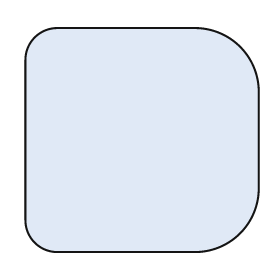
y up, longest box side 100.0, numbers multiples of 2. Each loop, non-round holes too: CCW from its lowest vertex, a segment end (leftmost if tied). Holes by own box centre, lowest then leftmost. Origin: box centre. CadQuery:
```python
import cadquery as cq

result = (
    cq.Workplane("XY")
    .moveTo(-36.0, -48.0)
    .lineTo(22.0, -48.0)
    .threePointArc((42.0, -40.0), (50.0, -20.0))
    .lineTo(50.0, 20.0)
    .threePointArc((42.0, 40.0), (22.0, 48.0))
    .lineTo(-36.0, 48.0)
    .threePointArc((-46.0, 44.0), (-50.0, 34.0))
    .lineTo(-50.0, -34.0)
    .threePointArc((-46.0, -44.0), (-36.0, -48.0))
    .close()
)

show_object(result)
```